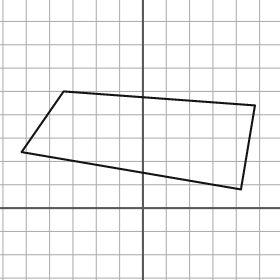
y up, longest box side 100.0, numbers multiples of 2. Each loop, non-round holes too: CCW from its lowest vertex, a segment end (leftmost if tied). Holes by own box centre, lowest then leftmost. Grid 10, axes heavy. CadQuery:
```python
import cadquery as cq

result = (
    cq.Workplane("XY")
    .moveTo(42.0, 8.0)
    .lineTo(48.0, 44.0)
    .lineTo(-34.0, 50.0)
    .lineTo(-52.0, 24.0)
    .close()
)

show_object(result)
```